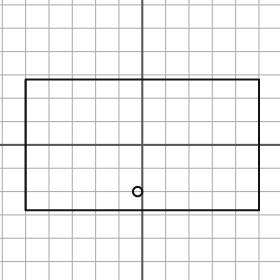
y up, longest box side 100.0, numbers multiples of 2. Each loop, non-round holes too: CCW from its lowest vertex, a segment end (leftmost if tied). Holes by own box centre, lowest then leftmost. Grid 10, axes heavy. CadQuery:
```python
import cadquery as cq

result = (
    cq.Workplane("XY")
    .moveTo(-50.0, -28.0)
    .lineTo(50.0, -28.0)
    .lineTo(50.0, 28.0)
    .lineTo(-50.0, 28.0)
    .close()
    .moveTo(-2.0, -20.0)
    .circle(2.0)
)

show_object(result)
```